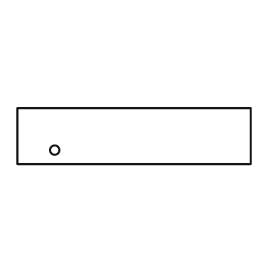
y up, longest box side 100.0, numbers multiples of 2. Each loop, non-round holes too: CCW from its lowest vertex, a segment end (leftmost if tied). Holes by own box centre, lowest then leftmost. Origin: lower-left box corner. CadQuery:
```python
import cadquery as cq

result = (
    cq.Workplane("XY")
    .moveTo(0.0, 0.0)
    .lineTo(100.0, 0.0)
    .lineTo(100.0, 24.0)
    .lineTo(0.0, 24.0)
    .close()
    .moveTo(16.0, 6.0)
    .circle(2.0)
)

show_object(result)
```